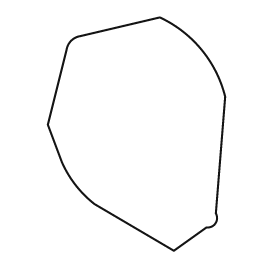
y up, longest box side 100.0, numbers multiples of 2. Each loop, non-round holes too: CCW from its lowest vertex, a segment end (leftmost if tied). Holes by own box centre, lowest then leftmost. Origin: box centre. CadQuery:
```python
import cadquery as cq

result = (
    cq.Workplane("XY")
    .moveTo(16.0, -50.0)
    .lineTo(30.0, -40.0)
    .threePointArc((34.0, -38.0), (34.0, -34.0))
    .lineTo(38.0, 16.0)
    .threePointArc((28.0, 36.0), (10.0, 50.0))
    .lineTo(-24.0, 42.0)
    .threePointArc((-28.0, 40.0), (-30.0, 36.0))
    .lineTo(-38.0, 4.0)
    .lineTo(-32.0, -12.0)
    .threePointArc((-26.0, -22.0), (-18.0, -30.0))
    .close()
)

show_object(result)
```